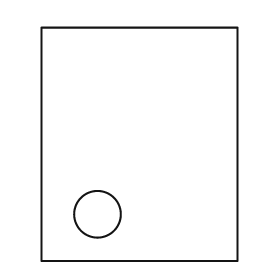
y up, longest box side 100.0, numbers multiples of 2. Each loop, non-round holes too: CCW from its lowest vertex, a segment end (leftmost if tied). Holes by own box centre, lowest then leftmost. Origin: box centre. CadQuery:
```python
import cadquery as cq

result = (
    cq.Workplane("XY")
    .moveTo(-42.0, -50.0)
    .lineTo(42.0, -50.0)
    .lineTo(42.0, 50.0)
    .lineTo(-42.0, 50.0)
    .close()
    .moveTo(-18.0, -30.0)
    .circle(10.0)
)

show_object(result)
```